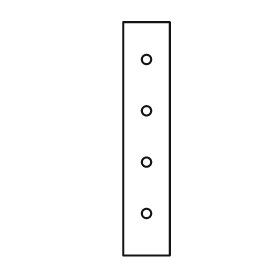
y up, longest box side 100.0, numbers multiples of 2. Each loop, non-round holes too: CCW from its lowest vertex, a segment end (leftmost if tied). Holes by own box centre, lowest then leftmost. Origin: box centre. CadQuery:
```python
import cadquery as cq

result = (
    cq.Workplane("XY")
    .moveTo(-10.0, -50.0)
    .lineTo(10.0, -50.0)
    .lineTo(10.0, 50.0)
    .lineTo(-10.0, 50.0)
    .close()
    .moveTo(0.0, -32.0)
    .circle(2.0)
    .moveTo(0.0, -10.0)
    .circle(2.0)
    .moveTo(0.0, 12.0)
    .circle(2.0)
    .moveTo(0.0, 34.0)
    .circle(2.0)
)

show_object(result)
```